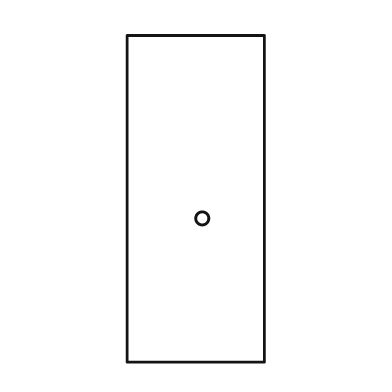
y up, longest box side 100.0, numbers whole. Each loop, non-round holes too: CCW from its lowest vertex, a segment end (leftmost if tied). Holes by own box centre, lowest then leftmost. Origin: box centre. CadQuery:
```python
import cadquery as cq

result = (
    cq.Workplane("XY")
    .moveTo(-21.0, -50.0)
    .lineTo(21.0, -50.0)
    .lineTo(21.0, 50.0)
    .lineTo(-21.0, 50.0)
    .close()
    .moveTo(2.0, -6.0)
    .circle(2.0)
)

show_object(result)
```